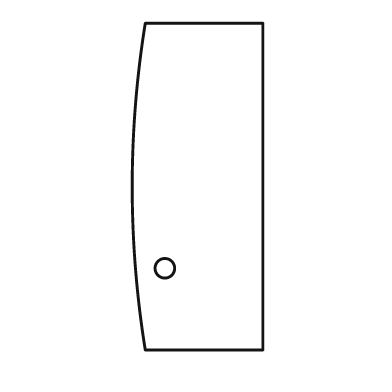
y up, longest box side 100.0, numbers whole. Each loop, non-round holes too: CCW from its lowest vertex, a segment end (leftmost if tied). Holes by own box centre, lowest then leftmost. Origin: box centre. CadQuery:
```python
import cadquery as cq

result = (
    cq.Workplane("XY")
    .moveTo(-16.0, -50.0)
    .lineTo(20.0, -50.0)
    .lineTo(20.0, 50.0)
    .lineTo(-16.0, 50.0)
    .threePointArc((-20.0, 0.0), (-16.0, -50.0))
    .close()
    .moveTo(-10.0, -25.0)
    .circle(3.0)
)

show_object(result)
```